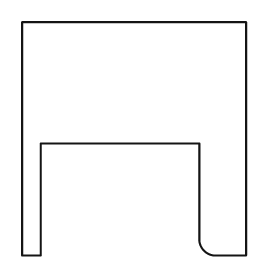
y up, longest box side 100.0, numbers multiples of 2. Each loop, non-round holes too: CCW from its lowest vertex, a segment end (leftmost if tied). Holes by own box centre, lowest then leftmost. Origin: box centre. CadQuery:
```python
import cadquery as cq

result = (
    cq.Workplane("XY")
    .moveTo(-48.0, -50.0)
    .lineTo(-40.0, -50.0)
    .lineTo(-40.0, -2.0)
    .lineTo(28.0, -2.0)
    .lineTo(28.0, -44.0)
    .threePointArc((30.0, -48.0), (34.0, -50.0))
    .lineTo(48.0, -50.0)
    .lineTo(48.0, 50.0)
    .lineTo(-48.0, 50.0)
    .close()
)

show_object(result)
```